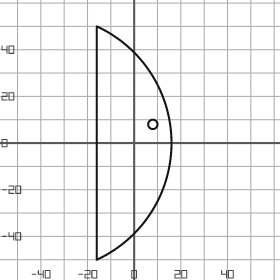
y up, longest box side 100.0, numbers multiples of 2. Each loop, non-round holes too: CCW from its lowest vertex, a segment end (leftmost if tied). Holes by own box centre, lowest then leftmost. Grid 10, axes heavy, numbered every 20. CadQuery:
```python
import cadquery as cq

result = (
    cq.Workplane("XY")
    .moveTo(-16.0, -50.0)
    .threePointArc((16.0, 0.0), (-16.0, 50.0))
    .close()
    .moveTo(8.0, 8.0)
    .circle(2.0)
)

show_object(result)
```